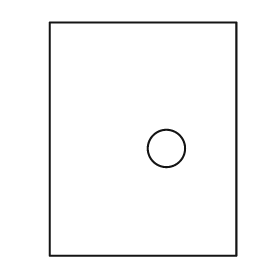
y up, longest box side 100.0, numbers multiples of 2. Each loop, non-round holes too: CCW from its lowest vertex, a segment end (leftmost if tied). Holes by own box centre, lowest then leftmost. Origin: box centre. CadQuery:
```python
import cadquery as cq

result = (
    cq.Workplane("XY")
    .moveTo(-40.0, -50.0)
    .lineTo(40.0, -50.0)
    .lineTo(40.0, 50.0)
    .lineTo(-40.0, 50.0)
    .close()
    .moveTo(10.0, -4.0)
    .circle(8.0)
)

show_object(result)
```